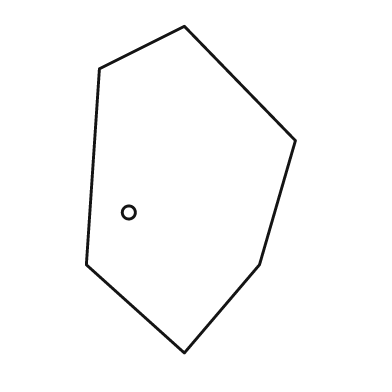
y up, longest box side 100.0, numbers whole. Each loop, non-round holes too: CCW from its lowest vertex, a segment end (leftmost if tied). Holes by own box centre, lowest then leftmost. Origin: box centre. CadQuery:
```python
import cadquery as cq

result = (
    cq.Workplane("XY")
    .moveTo(-2.0, -50.0)
    .lineTo(21.0, -23.0)
    .lineTo(32.0, 15.0)
    .lineTo(-2.0, 50.0)
    .lineTo(-28.0, 37.0)
    .lineTo(-32.0, -23.0)
    .close()
    .moveTo(-19.0, -7.0)
    .circle(2.0)
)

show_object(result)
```